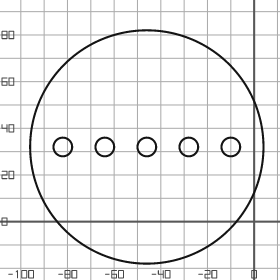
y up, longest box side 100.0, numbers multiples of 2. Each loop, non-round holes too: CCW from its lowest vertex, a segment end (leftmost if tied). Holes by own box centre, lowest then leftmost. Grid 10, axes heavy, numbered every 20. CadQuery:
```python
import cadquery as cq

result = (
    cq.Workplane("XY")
    .moveTo(-46.0, 32.0)
    .circle(50.0)
    .moveTo(-82.0, 32.0)
    .circle(4.0)
    .moveTo(-64.0, 32.0)
    .circle(4.0)
    .moveTo(-46.0, 32.0)
    .circle(4.0)
    .moveTo(-28.0, 32.0)
    .circle(4.0)
    .moveTo(-10.0, 32.0)
    .circle(4.0)
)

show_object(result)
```